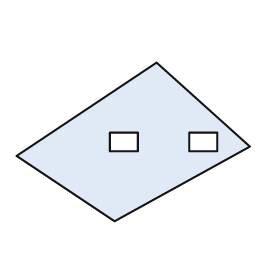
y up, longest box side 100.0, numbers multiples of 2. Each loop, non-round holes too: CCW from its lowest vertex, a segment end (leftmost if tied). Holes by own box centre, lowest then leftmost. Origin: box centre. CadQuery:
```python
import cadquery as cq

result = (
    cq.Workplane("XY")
    .moveTo(-8.0, -34.0)
    .lineTo(50.0, -2.0)
    .lineTo(10.0, 34.0)
    .lineTo(-50.0, -6.0)
    .close()
    .moveTo(-10.0, -4.0)
    .lineTo(2.0, -4.0)
    .lineTo(2.0, 4.0)
    .lineTo(-10.0, 4.0)
    .close()
    .moveTo(24.0, -4.0)
    .lineTo(36.0, -4.0)
    .lineTo(36.0, 4.0)
    .lineTo(24.0, 4.0)
    .close()
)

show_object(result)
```